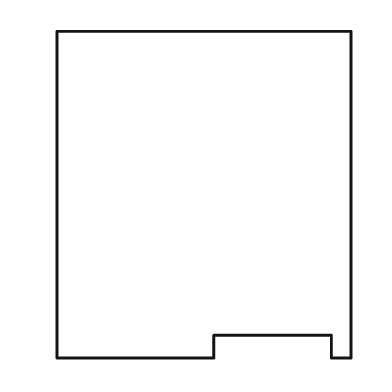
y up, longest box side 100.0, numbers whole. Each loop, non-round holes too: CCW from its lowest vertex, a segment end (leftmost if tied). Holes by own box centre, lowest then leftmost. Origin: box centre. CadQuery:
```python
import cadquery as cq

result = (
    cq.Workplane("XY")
    .moveTo(-45.0, -50.0)
    .lineTo(3.0, -50.0)
    .lineTo(3.0, -43.0)
    .lineTo(39.0, -43.0)
    .lineTo(39.0, -50.0)
    .lineTo(45.0, -50.0)
    .lineTo(45.0, 50.0)
    .lineTo(-45.0, 50.0)
    .close()
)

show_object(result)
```